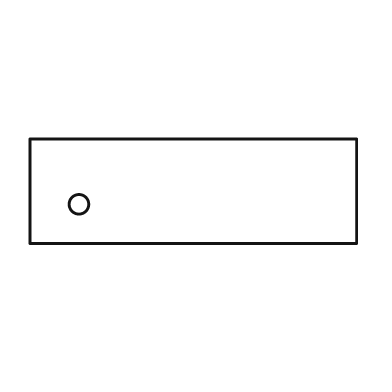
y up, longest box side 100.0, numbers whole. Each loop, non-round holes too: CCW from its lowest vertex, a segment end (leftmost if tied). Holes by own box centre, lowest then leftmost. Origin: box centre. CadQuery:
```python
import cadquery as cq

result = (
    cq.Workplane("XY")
    .moveTo(-50.0, -16.0)
    .lineTo(50.0, -16.0)
    .lineTo(50.0, 16.0)
    .lineTo(-50.0, 16.0)
    .close()
    .moveTo(-35.0, -4.0)
    .circle(3.0)
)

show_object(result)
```